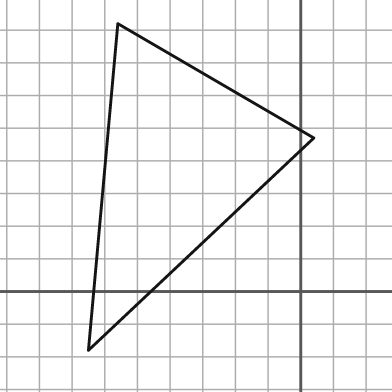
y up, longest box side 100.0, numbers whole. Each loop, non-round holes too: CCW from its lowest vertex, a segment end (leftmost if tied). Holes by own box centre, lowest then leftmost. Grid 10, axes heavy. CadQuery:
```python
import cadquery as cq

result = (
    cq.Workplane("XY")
    .moveTo(-65.0, -18.0)
    .lineTo(4.0, 47.0)
    .lineTo(-56.0, 82.0)
    .close()
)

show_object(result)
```